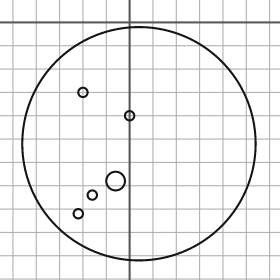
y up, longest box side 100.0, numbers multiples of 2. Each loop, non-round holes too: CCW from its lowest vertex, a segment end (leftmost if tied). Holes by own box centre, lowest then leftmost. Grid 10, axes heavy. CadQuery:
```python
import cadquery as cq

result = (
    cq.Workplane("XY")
    .moveTo(4.0, -52.0)
    .circle(50.0)
    .moveTo(-22.0, -82.0)
    .circle(2.0)
    .moveTo(-16.0, -74.0)
    .circle(2.0)
    .moveTo(-6.0, -68.0)
    .circle(4.0)
    .moveTo(0.0, -40.0)
    .circle(2.0)
    .moveTo(-20.0, -30.0)
    .circle(2.0)
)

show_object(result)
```